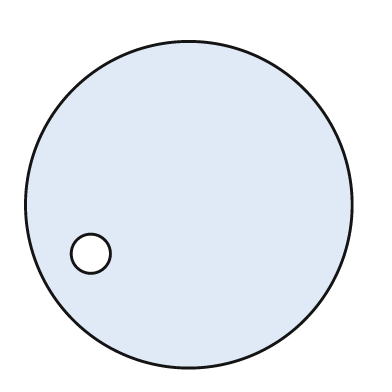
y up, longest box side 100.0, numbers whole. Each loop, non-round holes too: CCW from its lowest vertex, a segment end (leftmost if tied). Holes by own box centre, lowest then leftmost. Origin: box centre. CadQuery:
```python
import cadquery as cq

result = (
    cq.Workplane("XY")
    .moveTo(0.0, 0.0)
    .circle(50.0)
    .moveTo(-30.0, -15.0)
    .circle(6.0)
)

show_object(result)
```